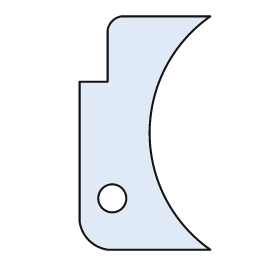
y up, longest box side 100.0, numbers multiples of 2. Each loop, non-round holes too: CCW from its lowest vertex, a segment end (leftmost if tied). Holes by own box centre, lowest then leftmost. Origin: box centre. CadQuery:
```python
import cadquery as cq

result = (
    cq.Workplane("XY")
    .moveTo(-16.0, -50.0)
    .lineTo(28.0, -50.0)
    .threePointArc((2.0, 0.0), (28.0, 50.0))
    .lineTo(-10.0, 50.0)
    .threePointArc((-14.0, 48.0), (-16.0, 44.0))
    .lineTo(-16.0, 22.0)
    .lineTo(-28.0, 22.0)
    .lineTo(-28.0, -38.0)
    .threePointArc((-24.0, -46.0), (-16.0, -50.0))
    .close()
    .moveTo(-14.0, -28.0)
    .circle(6.0)
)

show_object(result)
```